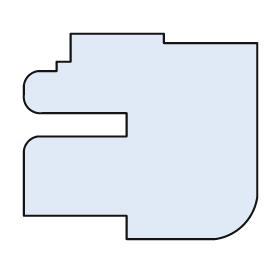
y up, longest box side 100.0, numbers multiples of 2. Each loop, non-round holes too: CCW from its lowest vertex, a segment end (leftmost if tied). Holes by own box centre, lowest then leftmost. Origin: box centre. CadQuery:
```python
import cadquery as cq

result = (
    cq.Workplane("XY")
    .moveTo(-6.0, -44.0)
    .lineTo(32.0, -44.0)
    .threePointArc((44.0, -38.0), (50.0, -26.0))
    .lineTo(50.0, 40.0)
    .lineTo(10.0, 40.0)
    .lineTo(10.0, 44.0)
    .lineTo(-30.0, 44.0)
    .lineTo(-30.0, 32.0)
    .lineTo(-36.0, 32.0)
    .lineTo(-36.0, 28.0)
    .lineTo(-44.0, 28.0)
    .threePointArc((-48.0, 26.0), (-50.0, 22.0))
    .lineTo(-50.0, 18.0)
    .threePointArc((-48.0, 12.0), (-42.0, 10.0))
    .lineTo(-6.0, 10.0)
    .lineTo(-6.0, 0.0)
    .lineTo(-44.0, 0.0)
    .threePointArc((-48.0, -2.0), (-50.0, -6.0))
    .lineTo(-50.0, -34.0)
    .lineTo(-6.0, -34.0)
    .close()
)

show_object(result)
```